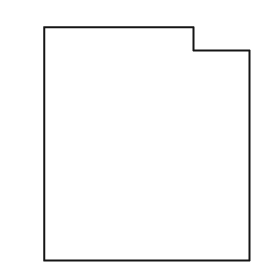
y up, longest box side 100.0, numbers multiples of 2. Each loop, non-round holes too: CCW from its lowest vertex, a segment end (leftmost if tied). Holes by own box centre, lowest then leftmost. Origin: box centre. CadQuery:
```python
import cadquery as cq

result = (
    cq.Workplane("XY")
    .moveTo(-44.0, -50.0)
    .lineTo(44.0, -50.0)
    .lineTo(44.0, 40.0)
    .lineTo(20.0, 40.0)
    .lineTo(20.0, 50.0)
    .lineTo(-44.0, 50.0)
    .close()
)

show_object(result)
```